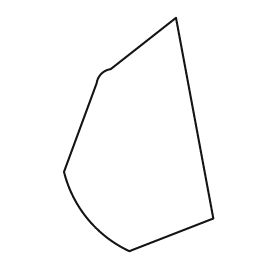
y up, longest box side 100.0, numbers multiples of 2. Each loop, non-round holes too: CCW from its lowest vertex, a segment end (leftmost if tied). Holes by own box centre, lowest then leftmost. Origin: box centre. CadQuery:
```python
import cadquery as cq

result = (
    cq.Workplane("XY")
    .moveTo(-4.0, -50.0)
    .lineTo(32.0, -36.0)
    .lineTo(16.0, 50.0)
    .lineTo(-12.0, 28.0)
    .threePointArc((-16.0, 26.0), (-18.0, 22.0))
    .lineTo(-32.0, -16.0)
    .threePointArc((-22.0, -36.0), (-4.0, -50.0))
    .close()
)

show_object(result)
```